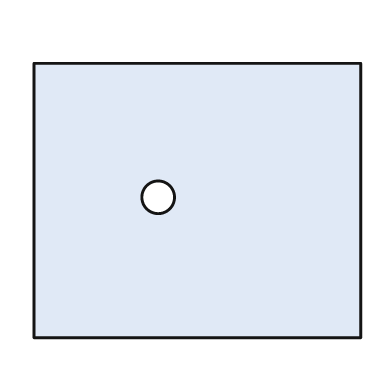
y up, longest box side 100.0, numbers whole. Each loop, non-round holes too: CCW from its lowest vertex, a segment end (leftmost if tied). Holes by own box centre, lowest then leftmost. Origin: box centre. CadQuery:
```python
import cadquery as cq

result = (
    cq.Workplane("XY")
    .moveTo(-50.0, -42.0)
    .lineTo(50.0, -42.0)
    .lineTo(50.0, 42.0)
    .lineTo(-50.0, 42.0)
    .close()
    .moveTo(-12.0, 1.0)
    .circle(5.0)
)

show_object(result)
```